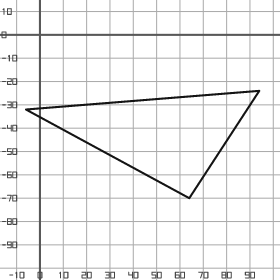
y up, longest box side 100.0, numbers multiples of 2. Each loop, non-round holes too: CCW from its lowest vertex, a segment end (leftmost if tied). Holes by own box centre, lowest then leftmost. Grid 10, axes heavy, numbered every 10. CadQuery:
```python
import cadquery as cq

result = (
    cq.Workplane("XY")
    .moveTo(64.0, -70.0)
    .lineTo(94.0, -24.0)
    .lineTo(-6.0, -32.0)
    .close()
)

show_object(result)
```